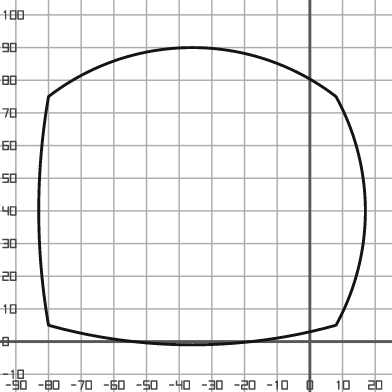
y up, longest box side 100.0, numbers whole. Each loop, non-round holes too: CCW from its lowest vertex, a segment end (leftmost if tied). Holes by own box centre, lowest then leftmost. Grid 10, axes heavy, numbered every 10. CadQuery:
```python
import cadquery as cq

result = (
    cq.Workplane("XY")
    .moveTo(-80.0, 5.0)
    .threePointArc((-36.0, -1.0), (8.0, 5.0))
    .threePointArc((17.0, 40.0), (8.0, 75.0))
    .threePointArc((-36.0, 90.0), (-80.0, 75.0))
    .threePointArc((-83.0, 40.0), (-80.0, 5.0))
    .close()
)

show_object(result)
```